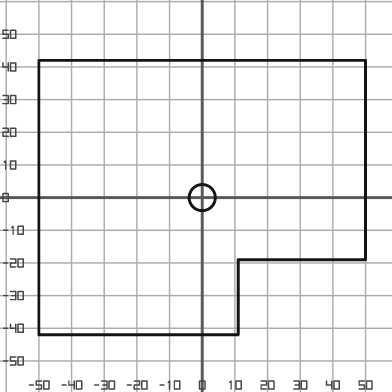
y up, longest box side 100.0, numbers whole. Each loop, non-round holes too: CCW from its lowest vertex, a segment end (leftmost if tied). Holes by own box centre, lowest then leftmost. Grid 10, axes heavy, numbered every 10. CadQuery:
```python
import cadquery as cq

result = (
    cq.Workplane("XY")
    .moveTo(-50.0, -42.0)
    .lineTo(11.0, -42.0)
    .lineTo(11.0, -19.0)
    .lineTo(50.0, -19.0)
    .lineTo(50.0, 42.0)
    .lineTo(-50.0, 42.0)
    .close()
    .moveTo(0.0, 0.0)
    .circle(4.0)
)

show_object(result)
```